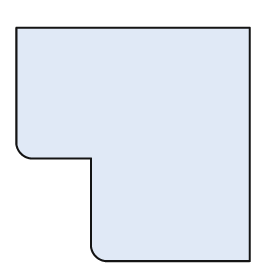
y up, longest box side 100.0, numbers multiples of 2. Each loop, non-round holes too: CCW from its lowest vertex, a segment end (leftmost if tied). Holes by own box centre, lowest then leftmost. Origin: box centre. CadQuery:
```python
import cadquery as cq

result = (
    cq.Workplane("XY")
    .moveTo(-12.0, -50.0)
    .lineTo(50.0, -50.0)
    .lineTo(50.0, 50.0)
    .lineTo(-50.0, 50.0)
    .lineTo(-50.0, 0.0)
    .threePointArc((-48.0, -4.0), (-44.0, -6.0))
    .lineTo(-18.0, -6.0)
    .lineTo(-18.0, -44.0)
    .threePointArc((-16.0, -48.0), (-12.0, -50.0))
    .close()
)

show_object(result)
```